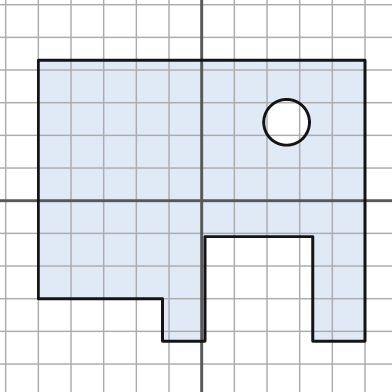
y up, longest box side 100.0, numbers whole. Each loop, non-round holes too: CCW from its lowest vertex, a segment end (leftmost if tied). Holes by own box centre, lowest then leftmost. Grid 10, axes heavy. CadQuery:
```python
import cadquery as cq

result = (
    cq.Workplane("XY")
    .moveTo(-12.0, -43.0)
    .lineTo(1.0, -43.0)
    .lineTo(1.0, -11.0)
    .lineTo(34.0, -11.0)
    .lineTo(34.0, -43.0)
    .lineTo(50.0, -43.0)
    .lineTo(50.0, 43.0)
    .lineTo(-50.0, 43.0)
    .lineTo(-50.0, -30.0)
    .lineTo(-12.0, -30.0)
    .close()
    .moveTo(26.0, 24.0)
    .circle(7.0)
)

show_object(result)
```